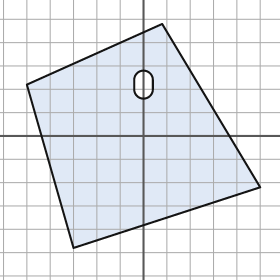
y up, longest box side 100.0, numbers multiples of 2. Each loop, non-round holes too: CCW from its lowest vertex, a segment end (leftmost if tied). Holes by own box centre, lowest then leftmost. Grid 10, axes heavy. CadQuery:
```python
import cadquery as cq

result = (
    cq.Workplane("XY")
    .moveTo(-30.0, -48.0)
    .lineTo(50.0, -22.0)
    .lineTo(8.0, 48.0)
    .lineTo(-50.0, 22.0)
    .close()
    .moveTo(-4.0, 20.0)
    .threePointArc((0.0, 16.0), (4.0, 20.0))
    .lineTo(4.0, 24.0)
    .threePointArc((0.0, 28.0), (-4.0, 24.0))
    .close()
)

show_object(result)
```